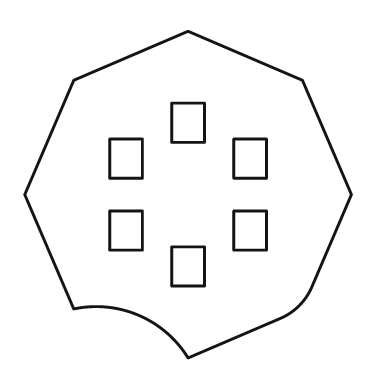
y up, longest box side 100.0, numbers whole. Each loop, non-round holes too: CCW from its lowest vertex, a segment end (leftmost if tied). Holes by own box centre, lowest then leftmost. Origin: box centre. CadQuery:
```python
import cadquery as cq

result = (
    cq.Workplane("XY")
    .moveTo(0.0, -50.0)
    .lineTo(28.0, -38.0)
    .threePointArc((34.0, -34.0), (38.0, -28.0))
    .lineTo(50.0, 0.0)
    .lineTo(35.0, 35.0)
    .lineTo(0.0, 50.0)
    .lineTo(-35.0, 35.0)
    .lineTo(-50.0, 0.0)
    .lineTo(-35.0, -35.0)
    .threePointArc((-15.0, -37.0), (0.0, -50.0))
    .close()
    .moveTo(-5.0, -28.0)
    .lineTo(5.0, -28.0)
    .lineTo(5.0, -16.0)
    .lineTo(-5.0, -16.0)
    .close()
    .moveTo(-24.0, -17.0)
    .lineTo(-14.0, -17.0)
    .lineTo(-14.0, -5.0)
    .lineTo(-24.0, -5.0)
    .close()
    .moveTo(14.0, -17.0)
    .lineTo(24.0, -17.0)
    .lineTo(24.0, -5.0)
    .lineTo(14.0, -5.0)
    .close()
    .moveTo(-24.0, 5.0)
    .lineTo(-14.0, 5.0)
    .lineTo(-14.0, 17.0)
    .lineTo(-24.0, 17.0)
    .close()
    .moveTo(14.0, 5.0)
    .lineTo(24.0, 5.0)
    .lineTo(24.0, 17.0)
    .lineTo(14.0, 17.0)
    .close()
    .moveTo(-5.0, 16.0)
    .lineTo(5.0, 16.0)
    .lineTo(5.0, 28.0)
    .lineTo(-5.0, 28.0)
    .close()
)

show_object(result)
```